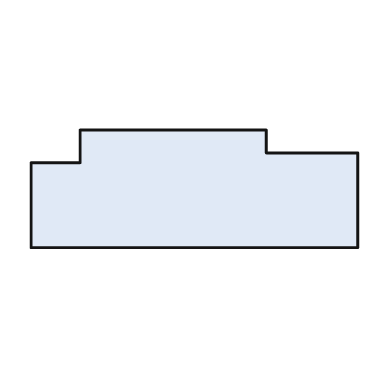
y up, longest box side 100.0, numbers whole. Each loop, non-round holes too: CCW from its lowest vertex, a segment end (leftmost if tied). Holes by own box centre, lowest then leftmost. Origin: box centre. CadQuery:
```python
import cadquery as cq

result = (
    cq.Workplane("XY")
    .moveTo(-50.0, -18.0)
    .lineTo(50.0, -18.0)
    .lineTo(50.0, 11.0)
    .lineTo(22.0, 11.0)
    .lineTo(22.0, 18.0)
    .lineTo(-35.0, 18.0)
    .lineTo(-35.0, 8.0)
    .lineTo(-50.0, 8.0)
    .close()
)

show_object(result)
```